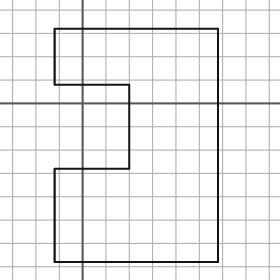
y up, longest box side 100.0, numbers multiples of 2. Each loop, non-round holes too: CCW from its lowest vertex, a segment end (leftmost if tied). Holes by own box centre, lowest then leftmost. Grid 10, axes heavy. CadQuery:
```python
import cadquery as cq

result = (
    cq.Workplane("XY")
    .moveTo(-12.0, -68.0)
    .lineTo(58.0, -68.0)
    .lineTo(58.0, 32.0)
    .lineTo(-12.0, 32.0)
    .lineTo(-12.0, 8.0)
    .lineTo(20.0, 8.0)
    .lineTo(20.0, -28.0)
    .lineTo(-12.0, -28.0)
    .close()
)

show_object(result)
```